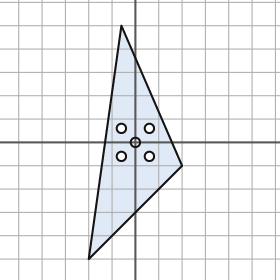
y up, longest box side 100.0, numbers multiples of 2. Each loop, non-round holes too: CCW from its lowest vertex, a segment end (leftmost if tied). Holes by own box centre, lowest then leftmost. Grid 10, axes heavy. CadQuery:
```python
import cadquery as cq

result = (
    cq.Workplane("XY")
    .moveTo(-20.0, -50.0)
    .lineTo(20.0, -10.0)
    .lineTo(-6.0, 50.0)
    .close()
    .moveTo(-6.0, -6.0)
    .circle(2.0)
    .moveTo(6.0, -6.0)
    .circle(2.0)
    .moveTo(0.0, 0.0)
    .circle(2.0)
    .moveTo(-6.0, 6.0)
    .circle(2.0)
    .moveTo(6.0, 6.0)
    .circle(2.0)
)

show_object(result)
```